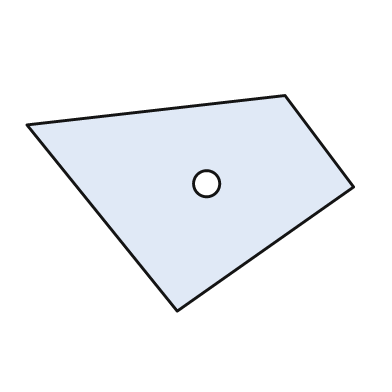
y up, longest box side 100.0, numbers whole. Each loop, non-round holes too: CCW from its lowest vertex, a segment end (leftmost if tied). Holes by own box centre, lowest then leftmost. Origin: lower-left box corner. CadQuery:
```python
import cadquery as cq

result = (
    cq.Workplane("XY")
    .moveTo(46.0, 0.0)
    .lineTo(100.0, 38.0)
    .lineTo(79.0, 66.0)
    .lineTo(0.0, 57.0)
    .close()
    .moveTo(55.0, 39.0)
    .circle(4.0)
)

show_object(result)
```